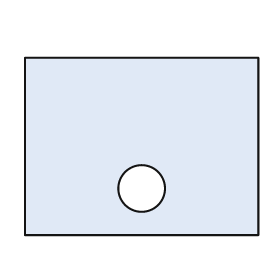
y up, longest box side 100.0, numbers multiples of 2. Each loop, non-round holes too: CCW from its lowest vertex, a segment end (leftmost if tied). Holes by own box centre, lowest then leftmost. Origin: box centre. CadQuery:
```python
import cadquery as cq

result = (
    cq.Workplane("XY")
    .moveTo(-50.0, -38.0)
    .lineTo(50.0, -38.0)
    .lineTo(50.0, 38.0)
    .lineTo(-50.0, 38.0)
    .close()
    .moveTo(0.0, -18.0)
    .circle(10.0)
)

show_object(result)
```